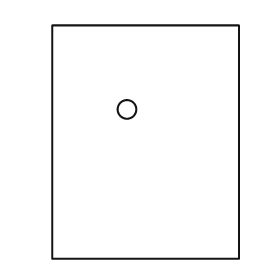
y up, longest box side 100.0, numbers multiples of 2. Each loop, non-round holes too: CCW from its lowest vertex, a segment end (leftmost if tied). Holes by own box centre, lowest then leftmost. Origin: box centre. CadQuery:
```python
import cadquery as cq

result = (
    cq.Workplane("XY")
    .moveTo(-40.0, -50.0)
    .lineTo(40.0, -50.0)
    .lineTo(40.0, 50.0)
    .lineTo(-40.0, 50.0)
    .close()
    .moveTo(-8.0, 14.0)
    .circle(4.0)
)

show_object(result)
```